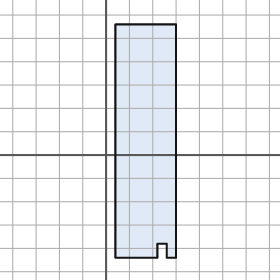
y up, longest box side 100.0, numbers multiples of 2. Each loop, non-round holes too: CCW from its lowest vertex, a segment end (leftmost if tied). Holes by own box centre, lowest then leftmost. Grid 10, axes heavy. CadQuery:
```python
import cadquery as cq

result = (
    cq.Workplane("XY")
    .moveTo(4.0, -44.0)
    .lineTo(22.0, -44.0)
    .lineTo(22.0, -38.0)
    .lineTo(26.0, -38.0)
    .lineTo(26.0, -44.0)
    .lineTo(30.0, -44.0)
    .lineTo(30.0, 56.0)
    .lineTo(4.0, 56.0)
    .close()
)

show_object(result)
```